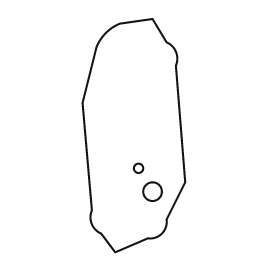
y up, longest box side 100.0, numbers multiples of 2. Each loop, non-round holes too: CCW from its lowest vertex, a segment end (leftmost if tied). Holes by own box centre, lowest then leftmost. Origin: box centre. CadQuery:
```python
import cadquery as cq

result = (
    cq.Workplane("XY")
    .moveTo(-8.0, -50.0)
    .lineTo(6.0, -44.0)
    .threePointArc((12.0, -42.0), (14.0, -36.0))
    .lineTo(22.0, -20.0)
    .lineTo(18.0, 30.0)
    .threePointArc((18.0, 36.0), (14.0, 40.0))
    .lineTo(8.0, 50.0)
    .lineTo(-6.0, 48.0)
    .threePointArc((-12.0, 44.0), (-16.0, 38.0))
    .lineTo(-22.0, 14.0)
    .lineTo(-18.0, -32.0)
    .threePointArc((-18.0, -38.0), (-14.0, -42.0))
    .close()
    .moveTo(8.0, -24.0)
    .circle(4.0)
    .moveTo(2.0, -14.0)
    .circle(2.0)
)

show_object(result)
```